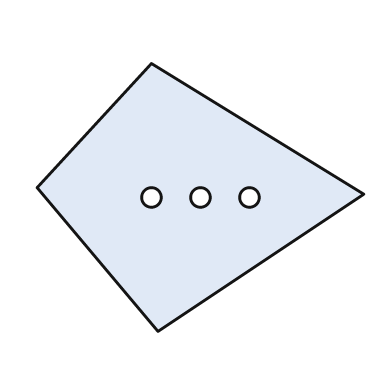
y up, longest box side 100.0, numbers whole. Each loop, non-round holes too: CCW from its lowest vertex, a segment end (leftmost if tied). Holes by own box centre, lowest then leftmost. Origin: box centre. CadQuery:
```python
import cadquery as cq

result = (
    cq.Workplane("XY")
    .moveTo(-13.0, -41.0)
    .lineTo(50.0, 1.0)
    .lineTo(-15.0, 41.0)
    .lineTo(-50.0, 3.0)
    .close()
    .moveTo(-15.0, 0.0)
    .circle(3.0)
    .moveTo(0.0, 0.0)
    .circle(3.0)
    .moveTo(15.0, 0.0)
    .circle(3.0)
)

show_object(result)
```